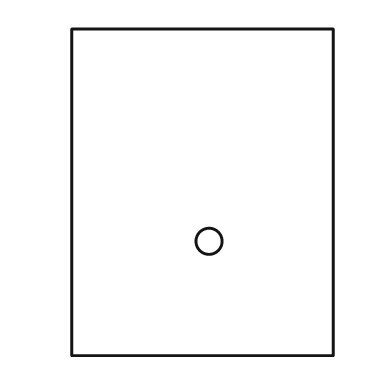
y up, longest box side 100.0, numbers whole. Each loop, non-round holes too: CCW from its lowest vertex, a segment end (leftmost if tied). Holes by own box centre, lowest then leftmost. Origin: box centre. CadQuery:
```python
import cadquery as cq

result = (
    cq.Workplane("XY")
    .moveTo(-40.0, -50.0)
    .lineTo(40.0, -50.0)
    .lineTo(40.0, 50.0)
    .lineTo(-40.0, 50.0)
    .close()
    .moveTo(2.0, -15.0)
    .circle(4.0)
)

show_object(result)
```